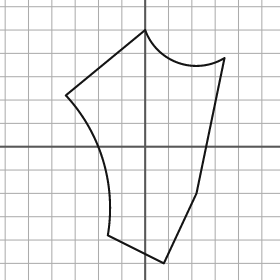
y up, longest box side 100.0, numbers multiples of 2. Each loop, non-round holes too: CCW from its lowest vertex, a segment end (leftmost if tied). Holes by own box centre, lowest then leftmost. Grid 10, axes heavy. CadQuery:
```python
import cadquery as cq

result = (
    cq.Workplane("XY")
    .moveTo(8.0, -50.0)
    .lineTo(22.0, -20.0)
    .lineTo(34.0, 38.0)
    .threePointArc((14.0, 36.0), (0.0, 50.0))
    .lineTo(-34.0, 22.0)
    .threePointArc((-18.0, -6.0), (-16.0, -38.0))
    .close()
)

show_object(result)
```